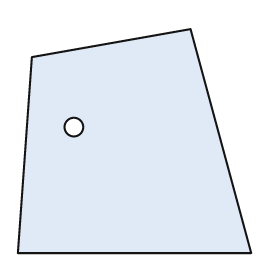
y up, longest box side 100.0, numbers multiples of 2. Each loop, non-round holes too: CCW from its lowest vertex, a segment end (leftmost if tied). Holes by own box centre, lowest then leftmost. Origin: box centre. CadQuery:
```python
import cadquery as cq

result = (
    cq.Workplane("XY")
    .moveTo(-50.0, -48.0)
    .lineTo(50.0, -48.0)
    .lineTo(24.0, 48.0)
    .lineTo(-44.0, 36.0)
    .close()
    .moveTo(-26.0, 6.0)
    .circle(4.0)
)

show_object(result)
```